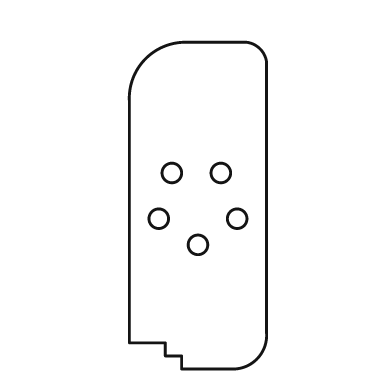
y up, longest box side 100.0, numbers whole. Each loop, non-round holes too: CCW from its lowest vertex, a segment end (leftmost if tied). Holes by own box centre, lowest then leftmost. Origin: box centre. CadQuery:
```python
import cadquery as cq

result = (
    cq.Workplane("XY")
    .moveTo(-5.0, -50.0)
    .lineTo(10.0, -50.0)
    .threePointArc((18.0, -47.0), (21.0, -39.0))
    .lineTo(21.0, 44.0)
    .threePointArc((19.0, 48.0), (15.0, 50.0))
    .lineTo(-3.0, 50.0)
    .threePointArc((-16.0, 45.0), (-21.0, 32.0))
    .lineTo(-21.0, -42.0)
    .lineTo(-10.0, -42.0)
    .lineTo(-10.0, -46.0)
    .lineTo(-5.0, -46.0)
    .close()
    .moveTo(0.0, -12.0)
    .circle(3.0)
    .moveTo(-12.0, -4.0)
    .circle(3.0)
    .moveTo(12.0, -4.0)
    .circle(3.0)
    .moveTo(-8.0, 10.0)
    .circle(3.0)
    .moveTo(7.0, 10.0)
    .circle(3.0)
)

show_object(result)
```